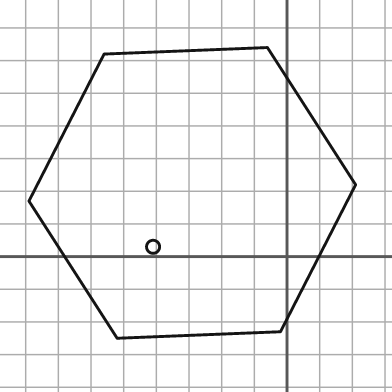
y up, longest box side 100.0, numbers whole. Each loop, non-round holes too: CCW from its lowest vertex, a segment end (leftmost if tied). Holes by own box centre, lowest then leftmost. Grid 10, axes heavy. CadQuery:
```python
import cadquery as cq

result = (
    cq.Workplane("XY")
    .moveTo(-52.0, -25.0)
    .lineTo(-2.0, -23.0)
    .lineTo(21.0, 22.0)
    .lineTo(-6.0, 64.0)
    .lineTo(-56.0, 62.0)
    .lineTo(-79.0, 17.0)
    .close()
    .moveTo(-41.0, 3.0)
    .circle(2.0)
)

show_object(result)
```